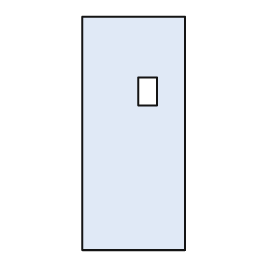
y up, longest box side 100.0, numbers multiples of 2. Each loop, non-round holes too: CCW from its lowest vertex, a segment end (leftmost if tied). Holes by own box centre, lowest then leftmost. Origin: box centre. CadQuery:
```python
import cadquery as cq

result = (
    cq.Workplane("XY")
    .moveTo(-22.0, -50.0)
    .lineTo(22.0, -50.0)
    .lineTo(22.0, 50.0)
    .lineTo(-22.0, 50.0)
    .close()
    .moveTo(2.0, 12.0)
    .lineTo(10.0, 12.0)
    .lineTo(10.0, 24.0)
    .lineTo(2.0, 24.0)
    .close()
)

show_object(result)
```